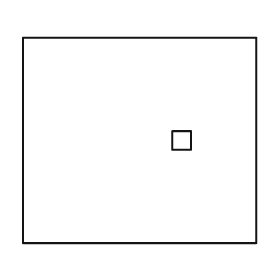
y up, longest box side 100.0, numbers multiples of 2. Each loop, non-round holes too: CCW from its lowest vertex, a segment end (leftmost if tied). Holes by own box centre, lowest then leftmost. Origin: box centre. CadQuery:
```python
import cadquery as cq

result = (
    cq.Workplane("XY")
    .moveTo(-50.0, -44.0)
    .lineTo(50.0, -44.0)
    .lineTo(50.0, 44.0)
    .lineTo(-50.0, 44.0)
    .close()
    .moveTo(14.0, -4.0)
    .lineTo(22.0, -4.0)
    .lineTo(22.0, 4.0)
    .lineTo(14.0, 4.0)
    .close()
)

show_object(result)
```